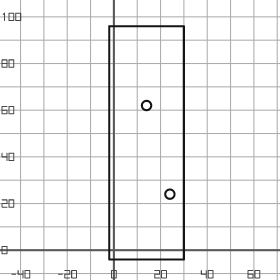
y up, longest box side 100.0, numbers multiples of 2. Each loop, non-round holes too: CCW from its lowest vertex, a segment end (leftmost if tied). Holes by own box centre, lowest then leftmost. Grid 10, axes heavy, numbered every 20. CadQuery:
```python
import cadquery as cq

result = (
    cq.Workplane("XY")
    .moveTo(-2.0, -4.0)
    .lineTo(30.0, -4.0)
    .lineTo(30.0, 96.0)
    .lineTo(-2.0, 96.0)
    .close()
    .moveTo(24.0, 24.0)
    .circle(2.0)
    .moveTo(14.0, 62.0)
    .circle(2.0)
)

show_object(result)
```